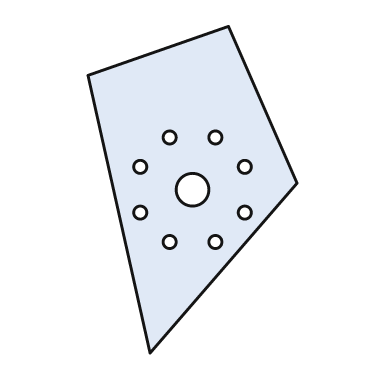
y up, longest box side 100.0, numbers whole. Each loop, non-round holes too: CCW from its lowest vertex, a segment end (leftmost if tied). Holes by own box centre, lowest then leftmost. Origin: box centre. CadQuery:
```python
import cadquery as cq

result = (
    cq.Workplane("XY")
    .moveTo(-13.0, -50.0)
    .lineTo(32.0, 2.0)
    .lineTo(11.0, 50.0)
    .lineTo(-32.0, 35.0)
    .close()
    .moveTo(-7.0, -16.0)
    .circle(2.0)
    .moveTo(7.0, -16.0)
    .circle(2.0)
    .moveTo(-16.0, -7.0)
    .circle(2.0)
    .moveTo(16.0, -7.0)
    .circle(2.0)
    .moveTo(0.0, 0.0)
    .circle(5.0)
    .moveTo(-16.0, 7.0)
    .circle(2.0)
    .moveTo(16.0, 7.0)
    .circle(2.0)
    .moveTo(-7.0, 16.0)
    .circle(2.0)
    .moveTo(7.0, 16.0)
    .circle(2.0)
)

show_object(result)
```